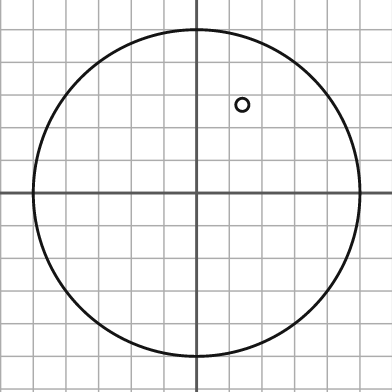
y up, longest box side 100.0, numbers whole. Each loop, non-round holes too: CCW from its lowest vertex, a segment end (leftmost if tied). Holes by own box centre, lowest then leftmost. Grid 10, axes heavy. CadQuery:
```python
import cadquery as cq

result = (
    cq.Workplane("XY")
    .moveTo(0.0, 0.0)
    .circle(50.0)
    .moveTo(14.0, 27.0)
    .circle(2.0)
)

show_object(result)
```